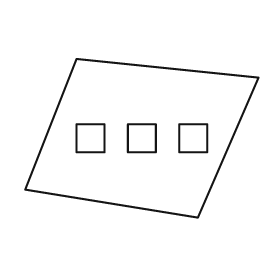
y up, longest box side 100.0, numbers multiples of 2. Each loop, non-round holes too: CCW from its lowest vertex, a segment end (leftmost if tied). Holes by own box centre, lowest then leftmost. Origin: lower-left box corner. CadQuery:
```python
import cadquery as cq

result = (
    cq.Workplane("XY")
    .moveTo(74.0, 0.0)
    .lineTo(100.0, 60.0)
    .lineTo(22.0, 68.0)
    .lineTo(0.0, 12.0)
    .close()
    .moveTo(22.0, 28.0)
    .lineTo(34.0, 28.0)
    .lineTo(34.0, 40.0)
    .lineTo(22.0, 40.0)
    .close()
    .moveTo(44.0, 28.0)
    .lineTo(56.0, 28.0)
    .lineTo(56.0, 40.0)
    .lineTo(44.0, 40.0)
    .close()
    .moveTo(66.0, 28.0)
    .lineTo(78.0, 28.0)
    .lineTo(78.0, 40.0)
    .lineTo(66.0, 40.0)
    .close()
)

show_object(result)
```